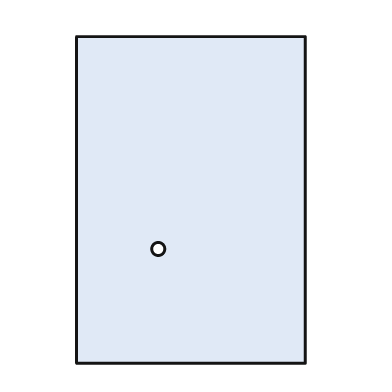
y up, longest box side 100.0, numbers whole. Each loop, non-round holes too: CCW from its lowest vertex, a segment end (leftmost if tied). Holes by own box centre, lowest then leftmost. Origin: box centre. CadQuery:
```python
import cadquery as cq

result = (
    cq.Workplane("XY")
    .moveTo(-35.0, -50.0)
    .lineTo(35.0, -50.0)
    .lineTo(35.0, 50.0)
    .lineTo(-35.0, 50.0)
    .close()
    .moveTo(-10.0, -15.0)
    .circle(2.0)
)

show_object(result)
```